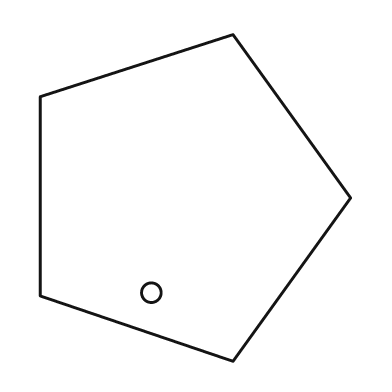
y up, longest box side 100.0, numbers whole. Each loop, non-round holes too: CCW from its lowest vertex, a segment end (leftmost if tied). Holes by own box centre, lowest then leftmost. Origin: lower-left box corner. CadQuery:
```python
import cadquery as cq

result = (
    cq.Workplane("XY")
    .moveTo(59.0, 0.0)
    .lineTo(95.0, 50.0)
    .lineTo(59.0, 100.0)
    .lineTo(0.0, 81.0)
    .lineTo(0.0, 20.0)
    .close()
    .moveTo(34.0, 21.0)
    .circle(3.0)
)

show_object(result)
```